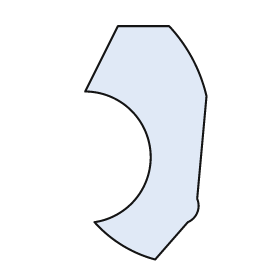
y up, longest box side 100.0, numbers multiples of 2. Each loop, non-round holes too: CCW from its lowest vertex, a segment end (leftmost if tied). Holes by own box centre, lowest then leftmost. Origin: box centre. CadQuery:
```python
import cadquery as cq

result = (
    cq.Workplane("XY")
    .moveTo(4.0, -50.0)
    .lineTo(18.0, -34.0)
    .threePointArc((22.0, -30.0), (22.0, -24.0))
    .lineTo(26.0, 20.0)
    .threePointArc((20.0, 36.0), (10.0, 50.0))
    .lineTo(-12.0, 50.0)
    .lineTo(-26.0, 22.0)
    .threePointArc((2.0, -4.0), (-22.0, -34.0))
    .threePointArc((-10.0, -44.0), (4.0, -50.0))
    .close()
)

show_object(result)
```